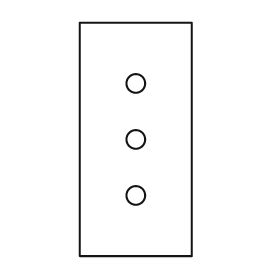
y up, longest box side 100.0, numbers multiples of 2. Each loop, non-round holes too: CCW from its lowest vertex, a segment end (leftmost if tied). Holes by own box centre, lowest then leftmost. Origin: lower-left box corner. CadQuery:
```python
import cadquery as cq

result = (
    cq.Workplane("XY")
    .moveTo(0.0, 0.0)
    .lineTo(48.0, 0.0)
    .lineTo(48.0, 100.0)
    .lineTo(0.0, 100.0)
    .close()
    .moveTo(24.0, 26.0)
    .circle(4.0)
    .moveTo(24.0, 50.0)
    .circle(4.0)
    .moveTo(24.0, 74.0)
    .circle(4.0)
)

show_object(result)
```